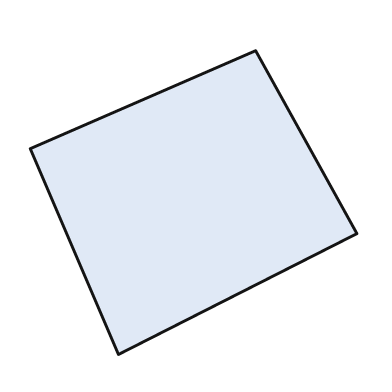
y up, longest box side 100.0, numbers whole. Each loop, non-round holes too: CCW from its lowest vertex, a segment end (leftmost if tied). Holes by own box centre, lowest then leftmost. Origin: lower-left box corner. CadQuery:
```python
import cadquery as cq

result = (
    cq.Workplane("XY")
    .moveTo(27.0, 0.0)
    .lineTo(100.0, 37.0)
    .lineTo(69.0, 93.0)
    .lineTo(0.0, 63.0)
    .close()
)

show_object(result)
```